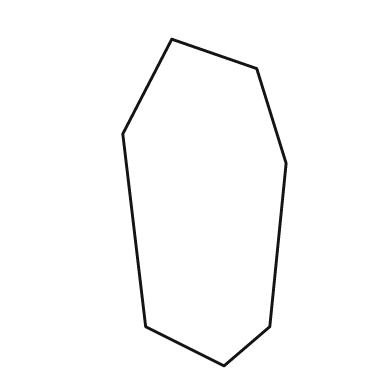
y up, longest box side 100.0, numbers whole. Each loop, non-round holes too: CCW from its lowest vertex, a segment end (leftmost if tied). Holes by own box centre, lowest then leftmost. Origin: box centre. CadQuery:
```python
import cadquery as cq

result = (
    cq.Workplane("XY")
    .moveTo(6.0, -50.0)
    .lineTo(20.0, -38.0)
    .lineTo(25.0, 12.0)
    .lineTo(16.0, 41.0)
    .lineTo(-10.0, 50.0)
    .lineTo(-25.0, 21.0)
    .lineTo(-18.0, -38.0)
    .close()
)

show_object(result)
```